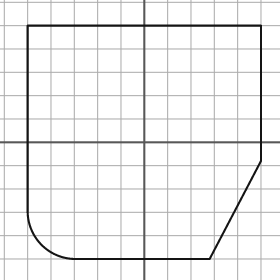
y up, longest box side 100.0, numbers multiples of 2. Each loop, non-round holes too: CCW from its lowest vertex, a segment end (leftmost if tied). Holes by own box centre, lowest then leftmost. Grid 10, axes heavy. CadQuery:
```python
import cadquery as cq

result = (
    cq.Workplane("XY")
    .moveTo(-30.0, -50.0)
    .lineTo(28.0, -50.0)
    .lineTo(50.0, -8.0)
    .lineTo(50.0, 50.0)
    .lineTo(-50.0, 50.0)
    .lineTo(-50.0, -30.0)
    .threePointArc((-44.0, -44.0), (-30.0, -50.0))
    .close()
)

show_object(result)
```